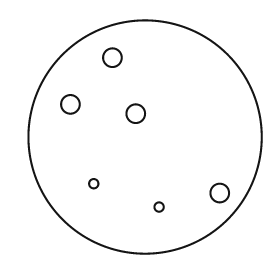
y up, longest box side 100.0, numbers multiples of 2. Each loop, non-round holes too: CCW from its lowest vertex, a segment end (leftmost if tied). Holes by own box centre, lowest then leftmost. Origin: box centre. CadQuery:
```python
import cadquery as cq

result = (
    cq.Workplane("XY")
    .moveTo(0.0, 0.0)
    .circle(50.0)
    .moveTo(6.0, -30.0)
    .circle(2.0)
    .moveTo(32.0, -24.0)
    .circle(4.0)
    .moveTo(-22.0, -20.0)
    .circle(2.0)
    .moveTo(-4.0, 10.0)
    .circle(4.0)
    .moveTo(-32.0, 14.0)
    .circle(4.0)
    .moveTo(-14.0, 34.0)
    .circle(4.0)
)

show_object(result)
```